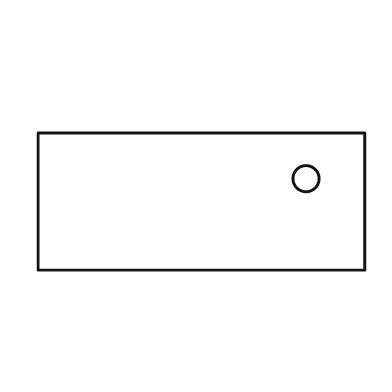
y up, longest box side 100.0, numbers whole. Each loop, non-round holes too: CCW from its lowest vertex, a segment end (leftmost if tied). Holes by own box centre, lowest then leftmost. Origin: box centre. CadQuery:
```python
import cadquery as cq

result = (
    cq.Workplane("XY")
    .moveTo(-50.0, -21.0)
    .lineTo(50.0, -21.0)
    .lineTo(50.0, 21.0)
    .lineTo(-50.0, 21.0)
    .close()
    .moveTo(32.0, 7.0)
    .circle(4.0)
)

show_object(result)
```